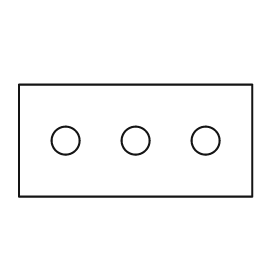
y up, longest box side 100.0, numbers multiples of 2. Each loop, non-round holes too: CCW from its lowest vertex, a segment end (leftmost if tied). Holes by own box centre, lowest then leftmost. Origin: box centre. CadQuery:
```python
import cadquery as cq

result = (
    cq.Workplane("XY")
    .moveTo(-50.0, -24.0)
    .lineTo(50.0, -24.0)
    .lineTo(50.0, 24.0)
    .lineTo(-50.0, 24.0)
    .close()
    .moveTo(-30.0, 0.0)
    .circle(6.0)
    .moveTo(0.0, 0.0)
    .circle(6.0)
    .moveTo(30.0, 0.0)
    .circle(6.0)
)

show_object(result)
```